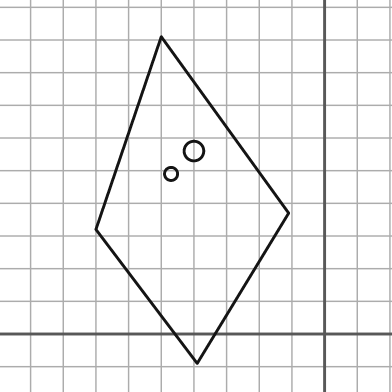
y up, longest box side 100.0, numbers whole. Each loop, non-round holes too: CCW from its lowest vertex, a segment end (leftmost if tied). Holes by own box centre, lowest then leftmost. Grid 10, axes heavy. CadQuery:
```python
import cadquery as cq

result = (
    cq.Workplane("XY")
    .moveTo(-39.0, -9.0)
    .lineTo(-11.0, 37.0)
    .lineTo(-50.0, 91.0)
    .lineTo(-70.0, 32.0)
    .close()
    .moveTo(-47.0, 49.0)
    .circle(2.0)
    .moveTo(-40.0, 56.0)
    .circle(3.0)
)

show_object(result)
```